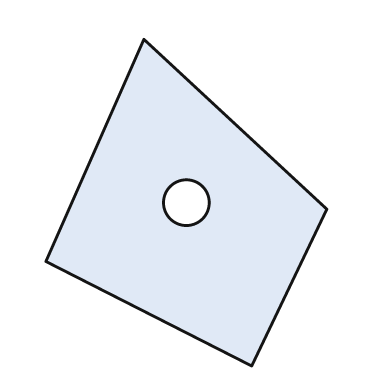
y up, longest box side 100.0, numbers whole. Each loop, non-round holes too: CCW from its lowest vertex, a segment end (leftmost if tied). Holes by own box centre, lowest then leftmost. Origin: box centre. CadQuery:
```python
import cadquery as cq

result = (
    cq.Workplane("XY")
    .moveTo(20.0, -50.0)
    .lineTo(43.0, -2.0)
    .lineTo(-13.0, 50.0)
    .lineTo(-43.0, -18.0)
    .close()
    .moveTo(0.0, 0.0)
    .circle(7.0)
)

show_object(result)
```